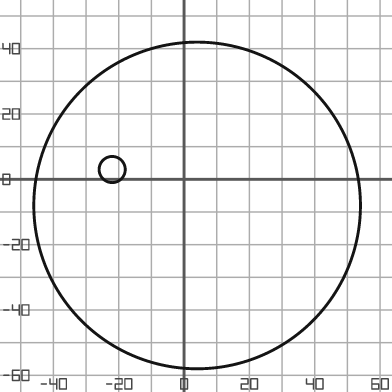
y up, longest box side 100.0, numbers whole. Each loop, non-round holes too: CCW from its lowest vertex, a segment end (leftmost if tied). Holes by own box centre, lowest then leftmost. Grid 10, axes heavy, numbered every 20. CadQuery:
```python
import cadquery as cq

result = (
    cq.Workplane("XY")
    .moveTo(4.0, -8.0)
    .circle(50.0)
    .moveTo(-22.0, 3.0)
    .circle(4.0)
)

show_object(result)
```